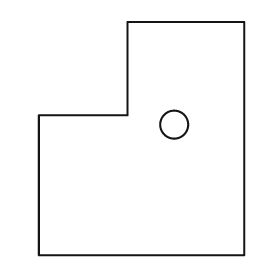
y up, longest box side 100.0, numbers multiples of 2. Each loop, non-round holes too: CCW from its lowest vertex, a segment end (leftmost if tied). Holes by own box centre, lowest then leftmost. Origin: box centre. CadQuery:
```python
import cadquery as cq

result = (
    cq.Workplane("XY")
    .moveTo(-44.0, -50.0)
    .lineTo(44.0, -50.0)
    .lineTo(44.0, 50.0)
    .lineTo(-6.0, 50.0)
    .lineTo(-6.0, 10.0)
    .lineTo(-44.0, 10.0)
    .close()
    .moveTo(14.0, 6.0)
    .circle(6.0)
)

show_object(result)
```